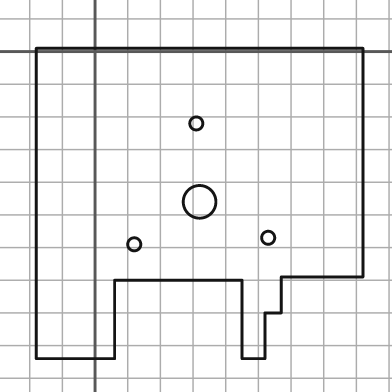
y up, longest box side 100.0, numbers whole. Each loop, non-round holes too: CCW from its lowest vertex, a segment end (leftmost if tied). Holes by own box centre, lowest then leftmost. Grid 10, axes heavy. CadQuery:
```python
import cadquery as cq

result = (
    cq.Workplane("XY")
    .moveTo(-18.0, -94.0)
    .lineTo(6.0, -94.0)
    .lineTo(6.0, -70.0)
    .lineTo(45.0, -70.0)
    .lineTo(45.0, -94.0)
    .lineTo(52.0, -94.0)
    .lineTo(52.0, -80.0)
    .lineTo(57.0, -80.0)
    .lineTo(57.0, -69.0)
    .lineTo(82.0, -69.0)
    .lineTo(82.0, 1.0)
    .lineTo(-18.0, 1.0)
    .close()
    .moveTo(12.0, -59.0)
    .circle(2.0)
    .moveTo(53.0, -57.0)
    .circle(2.0)
    .moveTo(32.0, -46.0)
    .circle(5.0)
    .moveTo(31.0, -22.0)
    .circle(2.0)
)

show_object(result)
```